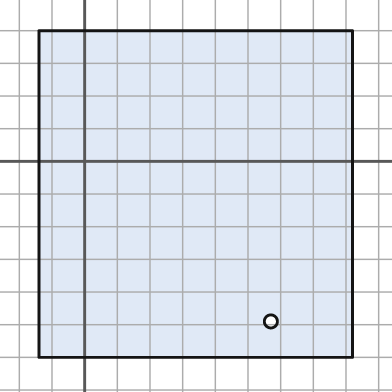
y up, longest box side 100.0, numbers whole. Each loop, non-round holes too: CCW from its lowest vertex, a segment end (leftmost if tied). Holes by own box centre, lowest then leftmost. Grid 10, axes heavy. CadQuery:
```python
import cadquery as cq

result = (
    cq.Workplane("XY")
    .moveTo(-14.0, -60.0)
    .lineTo(82.0, -60.0)
    .lineTo(82.0, 40.0)
    .lineTo(-14.0, 40.0)
    .close()
    .moveTo(57.0, -49.0)
    .circle(2.0)
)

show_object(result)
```